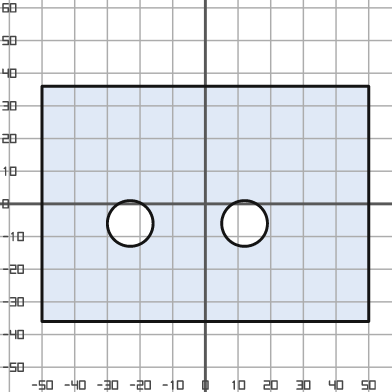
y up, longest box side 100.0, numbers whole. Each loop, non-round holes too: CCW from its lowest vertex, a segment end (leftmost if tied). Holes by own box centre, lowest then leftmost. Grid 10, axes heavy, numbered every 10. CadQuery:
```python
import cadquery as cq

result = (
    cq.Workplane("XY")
    .moveTo(-50.0, -36.0)
    .lineTo(50.0, -36.0)
    .lineTo(50.0, 36.0)
    .lineTo(-50.0, 36.0)
    .close()
    .moveTo(-23.0, -6.0)
    .circle(7.0)
    .moveTo(12.0, -6.0)
    .circle(7.0)
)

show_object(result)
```